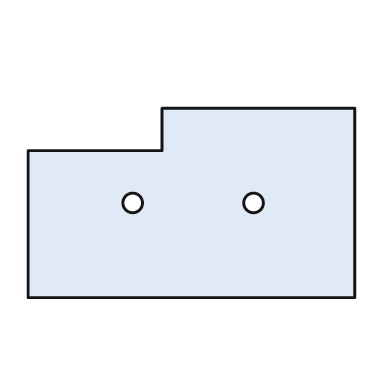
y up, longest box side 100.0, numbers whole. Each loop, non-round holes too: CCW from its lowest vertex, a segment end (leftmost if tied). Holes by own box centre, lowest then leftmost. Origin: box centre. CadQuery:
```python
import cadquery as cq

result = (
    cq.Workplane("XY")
    .moveTo(-50.0, -29.0)
    .lineTo(50.0, -29.0)
    .lineTo(50.0, 29.0)
    .lineTo(-9.0, 29.0)
    .lineTo(-9.0, 16.0)
    .lineTo(-50.0, 16.0)
    .close()
    .moveTo(-18.0, 0.0)
    .circle(3.0)
    .moveTo(19.0, 0.0)
    .circle(3.0)
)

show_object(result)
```